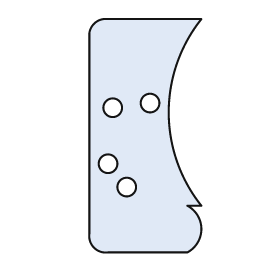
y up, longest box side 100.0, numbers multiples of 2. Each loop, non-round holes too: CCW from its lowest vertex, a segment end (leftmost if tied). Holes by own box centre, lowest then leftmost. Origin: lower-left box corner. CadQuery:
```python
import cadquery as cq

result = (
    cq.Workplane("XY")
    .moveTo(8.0, 0.0)
    .lineTo(42.0, 0.0)
    .threePointArc((48.0, 10.0), (42.0, 20.0))
    .lineTo(48.0, 20.0)
    .threePointArc((34.0, 60.0), (48.0, 100.0))
    .lineTo(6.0, 100.0)
    .threePointArc((2.0, 98.0), (0.0, 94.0))
    .lineTo(0.0, 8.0)
    .threePointArc((2.0, 2.0), (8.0, 0.0))
    .close()
    .moveTo(16.0, 28.0)
    .circle(4.0)
    .moveTo(8.0, 38.0)
    .circle(4.0)
    .moveTo(10.0, 62.0)
    .circle(4.0)
    .moveTo(26.0, 64.0)
    .circle(4.0)
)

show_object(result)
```